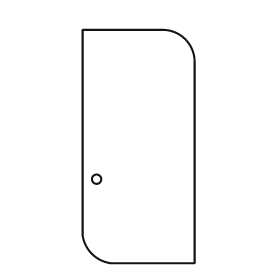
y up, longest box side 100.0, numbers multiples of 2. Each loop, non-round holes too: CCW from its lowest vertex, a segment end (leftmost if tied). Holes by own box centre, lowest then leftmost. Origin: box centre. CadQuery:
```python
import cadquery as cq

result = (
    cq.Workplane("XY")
    .moveTo(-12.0, -50.0)
    .lineTo(24.0, -50.0)
    .lineTo(24.0, 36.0)
    .threePointArc((20.0, 46.0), (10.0, 50.0))
    .lineTo(-24.0, 50.0)
    .lineTo(-24.0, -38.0)
    .threePointArc((-20.0, -46.0), (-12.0, -50.0))
    .close()
    .moveTo(-18.0, -14.0)
    .circle(2.0)
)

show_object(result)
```